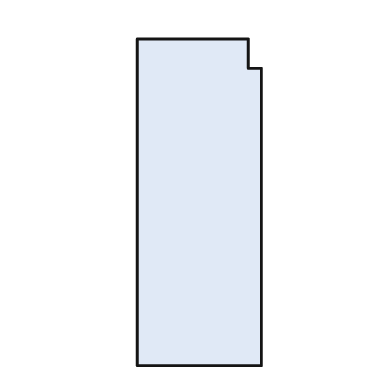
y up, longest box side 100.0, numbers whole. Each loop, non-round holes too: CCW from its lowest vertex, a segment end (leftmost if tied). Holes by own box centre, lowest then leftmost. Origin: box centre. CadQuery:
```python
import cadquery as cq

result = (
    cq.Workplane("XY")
    .moveTo(-19.0, -50.0)
    .lineTo(19.0, -50.0)
    .lineTo(19.0, 41.0)
    .lineTo(15.0, 41.0)
    .lineTo(15.0, 50.0)
    .lineTo(-19.0, 50.0)
    .close()
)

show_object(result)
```